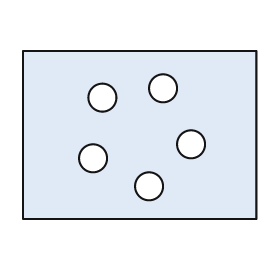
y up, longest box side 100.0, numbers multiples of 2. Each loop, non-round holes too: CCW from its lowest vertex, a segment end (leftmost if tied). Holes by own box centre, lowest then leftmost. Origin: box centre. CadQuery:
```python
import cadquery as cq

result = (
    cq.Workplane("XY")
    .moveTo(-50.0, -36.0)
    .lineTo(50.0, -36.0)
    .lineTo(50.0, 36.0)
    .lineTo(-50.0, 36.0)
    .close()
    .moveTo(4.0, -22.0)
    .circle(6.0)
    .moveTo(-20.0, -10.0)
    .circle(6.0)
    .moveTo(22.0, -4.0)
    .circle(6.0)
    .moveTo(-16.0, 16.0)
    .circle(6.0)
    .moveTo(10.0, 20.0)
    .circle(6.0)
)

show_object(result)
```